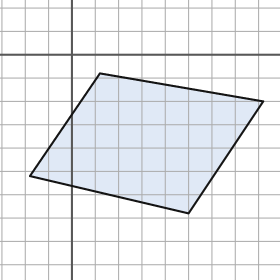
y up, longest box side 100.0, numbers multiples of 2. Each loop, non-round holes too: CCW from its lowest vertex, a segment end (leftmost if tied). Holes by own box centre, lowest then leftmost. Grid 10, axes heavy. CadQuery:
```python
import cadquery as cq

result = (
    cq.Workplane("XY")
    .moveTo(50.0, -68.0)
    .lineTo(82.0, -20.0)
    .lineTo(12.0, -8.0)
    .lineTo(-18.0, -52.0)
    .close()
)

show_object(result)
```